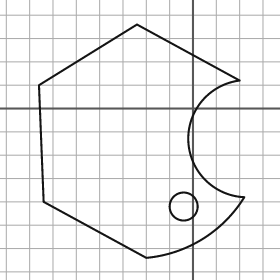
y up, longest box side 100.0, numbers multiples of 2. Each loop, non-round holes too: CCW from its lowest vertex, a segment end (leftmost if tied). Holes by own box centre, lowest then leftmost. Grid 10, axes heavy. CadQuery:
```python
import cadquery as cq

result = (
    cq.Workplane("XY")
    .moveTo(-20.0, -64.0)
    .threePointArc((4.0, -56.0), (22.0, -38.0))
    .threePointArc((-2.0, -14.0), (20.0, 12.0))
    .lineTo(-24.0, 36.0)
    .lineTo(-66.0, 10.0)
    .lineTo(-64.0, -40.0)
    .close()
    .moveTo(-4.0, -42.0)
    .circle(6.0)
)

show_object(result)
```